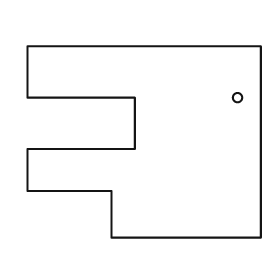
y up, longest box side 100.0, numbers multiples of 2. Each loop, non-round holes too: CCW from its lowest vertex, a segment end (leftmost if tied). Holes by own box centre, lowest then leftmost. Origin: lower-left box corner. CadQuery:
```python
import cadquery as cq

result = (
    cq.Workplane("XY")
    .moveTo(36.0, 0.0)
    .lineTo(100.0, 0.0)
    .lineTo(100.0, 82.0)
    .lineTo(0.0, 82.0)
    .lineTo(0.0, 60.0)
    .lineTo(46.0, 60.0)
    .lineTo(46.0, 38.0)
    .lineTo(0.0, 38.0)
    .lineTo(0.0, 20.0)
    .lineTo(36.0, 20.0)
    .close()
    .moveTo(90.0, 60.0)
    .circle(2.0)
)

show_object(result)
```